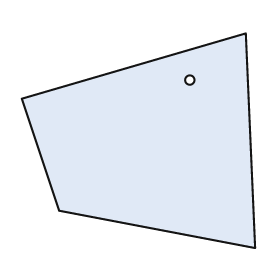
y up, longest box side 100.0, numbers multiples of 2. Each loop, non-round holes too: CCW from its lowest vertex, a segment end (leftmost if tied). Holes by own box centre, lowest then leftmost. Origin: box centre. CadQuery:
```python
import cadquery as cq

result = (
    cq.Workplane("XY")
    .moveTo(50.0, -46.0)
    .lineTo(46.0, 46.0)
    .lineTo(-50.0, 18.0)
    .lineTo(-34.0, -30.0)
    .close()
    .moveTo(22.0, 26.0)
    .circle(2.0)
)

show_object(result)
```